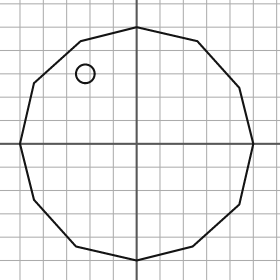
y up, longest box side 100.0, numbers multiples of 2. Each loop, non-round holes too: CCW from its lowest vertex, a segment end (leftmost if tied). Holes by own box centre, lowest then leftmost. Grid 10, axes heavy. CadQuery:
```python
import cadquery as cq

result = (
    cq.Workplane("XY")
    .moveTo(0.0, -50.0)
    .lineTo(24.0, -44.0)
    .lineTo(44.0, -26.0)
    .lineTo(50.0, 0.0)
    .lineTo(44.0, 24.0)
    .lineTo(26.0, 44.0)
    .lineTo(0.0, 50.0)
    .lineTo(-24.0, 44.0)
    .lineTo(-44.0, 26.0)
    .lineTo(-50.0, 0.0)
    .lineTo(-44.0, -24.0)
    .lineTo(-26.0, -44.0)
    .close()
    .moveTo(-22.0, 30.0)
    .circle(4.0)
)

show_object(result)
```